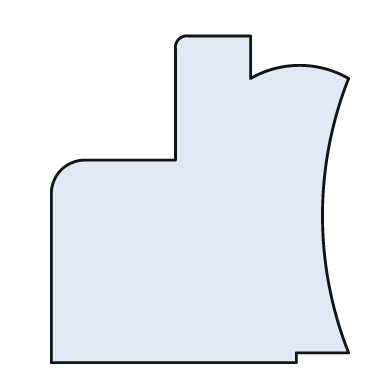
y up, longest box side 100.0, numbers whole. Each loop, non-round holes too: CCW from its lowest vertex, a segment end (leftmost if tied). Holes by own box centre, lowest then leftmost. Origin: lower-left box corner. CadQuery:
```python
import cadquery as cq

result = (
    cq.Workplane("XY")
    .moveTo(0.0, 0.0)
    .lineTo(75.0, 0.0)
    .lineTo(75.0, 3.0)
    .lineTo(91.0, 3.0)
    .threePointArc((83.0, 45.0), (91.0, 87.0))
    .threePointArc((76.0, 91.0), (61.0, 87.0))
    .lineTo(61.0, 100.0)
    .lineTo(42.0, 100.0)
    .threePointArc((39.0, 99.0), (38.0, 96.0))
    .lineTo(38.0, 62.0)
    .lineTo(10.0, 62.0)
    .threePointArc((3.0, 59.0), (0.0, 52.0))
    .close()
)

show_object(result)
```